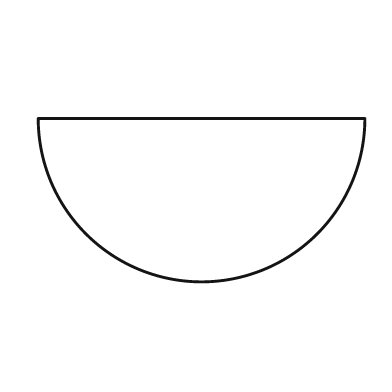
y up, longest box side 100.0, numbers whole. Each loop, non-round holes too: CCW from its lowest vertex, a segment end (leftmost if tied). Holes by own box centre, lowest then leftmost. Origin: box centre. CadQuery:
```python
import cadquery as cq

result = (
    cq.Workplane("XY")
    .moveTo(-50.0, 25.0)
    .threePointArc((0.0, -25.0), (50.0, 25.0))
    .close()
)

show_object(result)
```